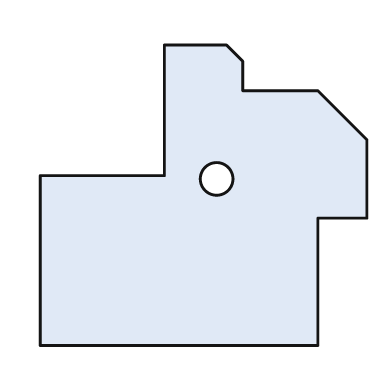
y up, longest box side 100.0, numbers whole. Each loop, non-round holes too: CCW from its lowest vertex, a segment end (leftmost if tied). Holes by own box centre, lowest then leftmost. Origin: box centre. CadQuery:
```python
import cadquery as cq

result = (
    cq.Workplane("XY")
    .moveTo(-50.0, -46.0)
    .lineTo(35.0, -46.0)
    .lineTo(35.0, -7.0)
    .lineTo(50.0, -7.0)
    .lineTo(50.0, 17.0)
    .lineTo(35.0, 32.0)
    .lineTo(12.0, 32.0)
    .lineTo(12.0, 41.0)
    .lineTo(7.0, 46.0)
    .lineTo(-12.0, 46.0)
    .lineTo(-12.0, 6.0)
    .lineTo(-50.0, 6.0)
    .close()
    .moveTo(4.0, 5.0)
    .circle(5.0)
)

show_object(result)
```